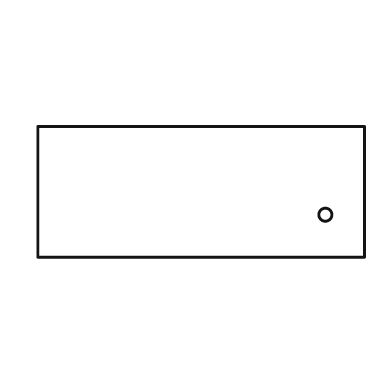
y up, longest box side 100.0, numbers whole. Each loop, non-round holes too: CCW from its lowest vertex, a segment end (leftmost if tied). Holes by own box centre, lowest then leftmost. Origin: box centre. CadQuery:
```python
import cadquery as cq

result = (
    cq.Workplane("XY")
    .moveTo(-50.0, -20.0)
    .lineTo(50.0, -20.0)
    .lineTo(50.0, 20.0)
    .lineTo(-50.0, 20.0)
    .close()
    .moveTo(38.0, -7.0)
    .circle(2.0)
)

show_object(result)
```